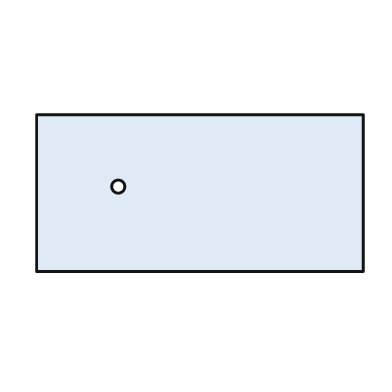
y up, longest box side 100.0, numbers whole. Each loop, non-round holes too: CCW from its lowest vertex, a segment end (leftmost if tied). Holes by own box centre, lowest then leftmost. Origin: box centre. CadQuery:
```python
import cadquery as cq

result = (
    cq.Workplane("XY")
    .moveTo(-50.0, -24.0)
    .lineTo(50.0, -24.0)
    .lineTo(50.0, 24.0)
    .lineTo(-50.0, 24.0)
    .close()
    .moveTo(-25.0, 2.0)
    .circle(2.0)
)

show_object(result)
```